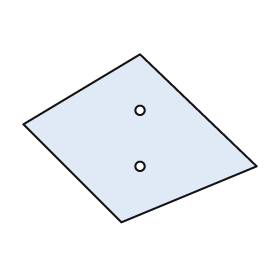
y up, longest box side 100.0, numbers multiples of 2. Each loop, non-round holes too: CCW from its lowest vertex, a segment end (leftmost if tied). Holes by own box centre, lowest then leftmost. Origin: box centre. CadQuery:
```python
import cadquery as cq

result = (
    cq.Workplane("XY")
    .moveTo(-8.0, -36.0)
    .lineTo(50.0, -12.0)
    .lineTo(0.0, 36.0)
    .lineTo(-50.0, 6.0)
    .close()
    .moveTo(0.0, -12.0)
    .circle(2.0)
    .moveTo(0.0, 12.0)
    .circle(2.0)
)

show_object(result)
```